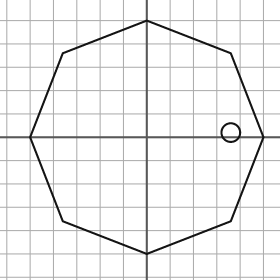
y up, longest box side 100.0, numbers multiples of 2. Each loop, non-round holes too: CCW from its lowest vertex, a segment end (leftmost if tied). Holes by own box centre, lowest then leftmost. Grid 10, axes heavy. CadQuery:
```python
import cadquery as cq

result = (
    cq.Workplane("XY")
    .moveTo(0.0, -50.0)
    .lineTo(36.0, -36.0)
    .lineTo(50.0, 0.0)
    .lineTo(36.0, 36.0)
    .lineTo(0.0, 50.0)
    .lineTo(-36.0, 36.0)
    .lineTo(-50.0, 0.0)
    .lineTo(-36.0, -36.0)
    .close()
    .moveTo(36.0, 2.0)
    .circle(4.0)
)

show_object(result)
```